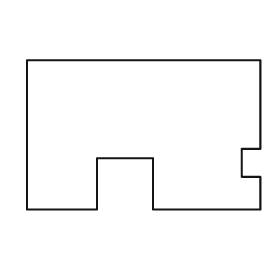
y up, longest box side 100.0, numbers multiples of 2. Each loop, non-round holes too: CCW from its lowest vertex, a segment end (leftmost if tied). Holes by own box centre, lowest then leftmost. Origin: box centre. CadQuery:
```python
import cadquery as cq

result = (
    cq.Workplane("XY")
    .moveTo(-50.0, -32.0)
    .lineTo(-20.0, -32.0)
    .lineTo(-20.0, -10.0)
    .lineTo(4.0, -10.0)
    .lineTo(4.0, -32.0)
    .lineTo(50.0, -32.0)
    .lineTo(50.0, -18.0)
    .lineTo(42.0, -18.0)
    .lineTo(42.0, -6.0)
    .lineTo(50.0, -6.0)
    .lineTo(50.0, 32.0)
    .lineTo(-50.0, 32.0)
    .close()
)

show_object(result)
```